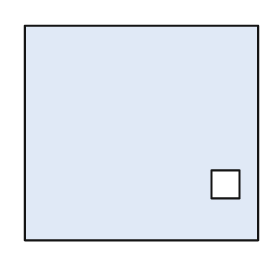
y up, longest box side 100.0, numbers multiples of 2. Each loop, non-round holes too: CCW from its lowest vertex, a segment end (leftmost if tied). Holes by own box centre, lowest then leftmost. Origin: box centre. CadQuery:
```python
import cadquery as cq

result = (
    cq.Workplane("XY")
    .moveTo(-50.0, -46.0)
    .lineTo(50.0, -46.0)
    .lineTo(50.0, 46.0)
    .lineTo(-50.0, 46.0)
    .close()
    .moveTo(30.0, -28.0)
    .lineTo(42.0, -28.0)
    .lineTo(42.0, -16.0)
    .lineTo(30.0, -16.0)
    .close()
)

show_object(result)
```